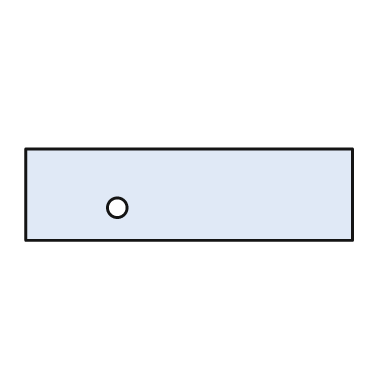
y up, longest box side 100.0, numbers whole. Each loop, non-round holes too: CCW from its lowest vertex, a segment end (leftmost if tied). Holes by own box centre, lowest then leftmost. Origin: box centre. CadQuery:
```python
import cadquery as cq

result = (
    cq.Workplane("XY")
    .moveTo(-50.0, -14.0)
    .lineTo(50.0, -14.0)
    .lineTo(50.0, 14.0)
    .lineTo(-50.0, 14.0)
    .close()
    .moveTo(-22.0, -4.0)
    .circle(3.0)
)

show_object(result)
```